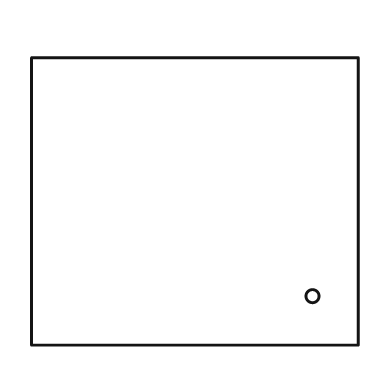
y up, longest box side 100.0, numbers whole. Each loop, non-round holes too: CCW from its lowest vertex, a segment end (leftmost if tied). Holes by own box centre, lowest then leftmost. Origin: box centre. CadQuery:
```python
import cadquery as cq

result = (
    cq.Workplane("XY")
    .moveTo(-50.0, -44.0)
    .lineTo(50.0, -44.0)
    .lineTo(50.0, 44.0)
    .lineTo(-50.0, 44.0)
    .close()
    .moveTo(36.0, -29.0)
    .circle(2.0)
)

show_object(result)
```